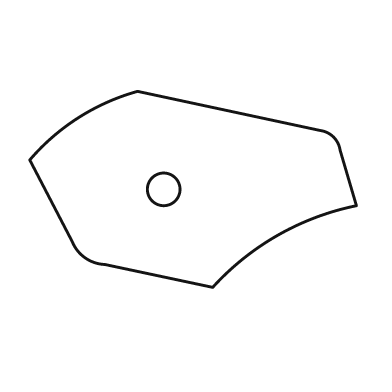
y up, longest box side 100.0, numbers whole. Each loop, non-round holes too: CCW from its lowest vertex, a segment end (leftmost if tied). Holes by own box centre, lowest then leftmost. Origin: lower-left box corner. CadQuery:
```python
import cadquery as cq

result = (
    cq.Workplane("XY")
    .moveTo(56.0, 0.0)
    .threePointArc((76.0, 16.0), (100.0, 25.0))
    .lineTo(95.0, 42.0)
    .threePointArc((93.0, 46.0), (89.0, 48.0))
    .lineTo(33.0, 60.0)
    .threePointArc((15.0, 52.0), (0.0, 39.0))
    .lineTo(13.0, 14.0)
    .threePointArc((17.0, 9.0), (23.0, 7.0))
    .close()
    .moveTo(41.0, 30.0)
    .circle(5.0)
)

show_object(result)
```